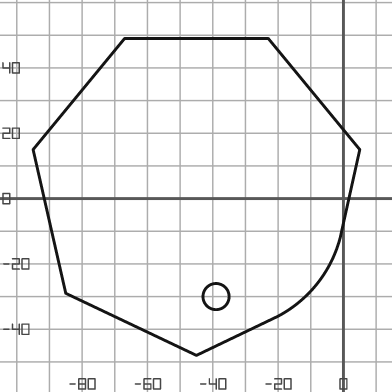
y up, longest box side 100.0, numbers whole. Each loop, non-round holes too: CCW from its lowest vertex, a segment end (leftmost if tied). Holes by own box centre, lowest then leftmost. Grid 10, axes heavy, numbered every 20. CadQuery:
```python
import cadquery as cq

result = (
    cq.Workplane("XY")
    .moveTo(-45.0, -48.0)
    .lineTo(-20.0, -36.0)
    .threePointArc((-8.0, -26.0), (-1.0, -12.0))
    .lineTo(5.0, 15.0)
    .lineTo(-23.0, 49.0)
    .lineTo(-67.0, 49.0)
    .lineTo(-95.0, 15.0)
    .lineTo(-85.0, -29.0)
    .close()
    .moveTo(-39.0, -30.0)
    .circle(4.0)
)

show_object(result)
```